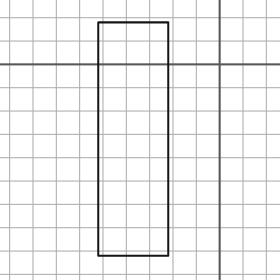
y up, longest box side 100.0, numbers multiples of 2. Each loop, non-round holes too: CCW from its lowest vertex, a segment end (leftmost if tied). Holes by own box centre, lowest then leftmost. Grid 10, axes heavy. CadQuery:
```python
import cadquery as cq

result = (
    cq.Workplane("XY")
    .moveTo(-52.0, -82.0)
    .lineTo(-22.0, -82.0)
    .lineTo(-22.0, 18.0)
    .lineTo(-52.0, 18.0)
    .close()
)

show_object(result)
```